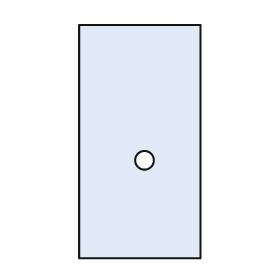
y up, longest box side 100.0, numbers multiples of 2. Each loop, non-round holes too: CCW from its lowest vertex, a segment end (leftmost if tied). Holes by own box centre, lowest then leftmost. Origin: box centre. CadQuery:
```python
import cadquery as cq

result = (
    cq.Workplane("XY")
    .moveTo(-26.0, -50.0)
    .lineTo(26.0, -50.0)
    .lineTo(26.0, 50.0)
    .lineTo(-26.0, 50.0)
    .close()
    .moveTo(2.0, -8.0)
    .circle(4.0)
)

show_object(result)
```